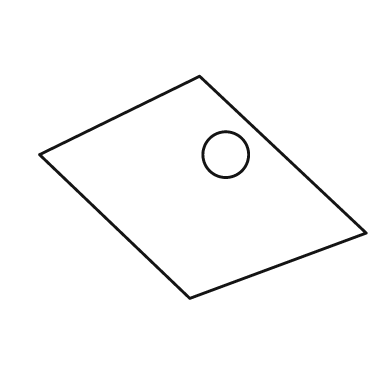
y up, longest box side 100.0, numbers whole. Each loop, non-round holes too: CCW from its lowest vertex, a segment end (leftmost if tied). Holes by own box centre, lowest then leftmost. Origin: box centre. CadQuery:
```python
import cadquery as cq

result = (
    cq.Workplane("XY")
    .moveTo(-4.0, -34.0)
    .lineTo(50.0, -14.0)
    .lineTo(-1.0, 34.0)
    .lineTo(-50.0, 10.0)
    .close()
    .moveTo(7.0, 10.0)
    .circle(7.0)
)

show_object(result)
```